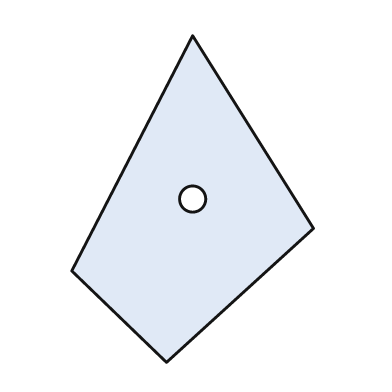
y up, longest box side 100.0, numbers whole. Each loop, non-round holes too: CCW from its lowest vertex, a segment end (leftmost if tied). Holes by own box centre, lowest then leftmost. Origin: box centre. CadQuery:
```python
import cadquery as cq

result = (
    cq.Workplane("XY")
    .moveTo(-8.0, -50.0)
    .lineTo(37.0, -9.0)
    .lineTo(0.0, 50.0)
    .lineTo(-37.0, -22.0)
    .close()
    .moveTo(0.0, 0.0)
    .circle(4.0)
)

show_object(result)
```